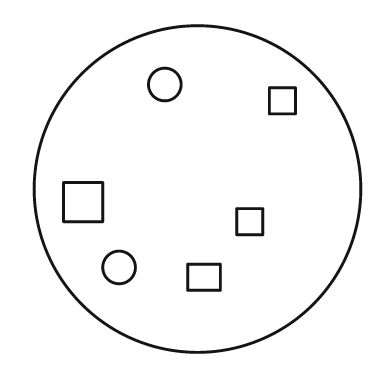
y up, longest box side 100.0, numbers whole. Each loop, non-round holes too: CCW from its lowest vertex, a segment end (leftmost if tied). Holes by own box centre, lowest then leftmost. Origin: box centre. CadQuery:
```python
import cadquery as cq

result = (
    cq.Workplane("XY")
    .moveTo(0.0, 0.0)
    .circle(50.0)
    .moveTo(-3.0, -31.0)
    .lineTo(7.0, -31.0)
    .lineTo(7.0, -23.0)
    .lineTo(-3.0, -23.0)
    .close()
    .moveTo(-24.0, -24.0)
    .circle(5.0)
    .moveTo(12.0, -14.0)
    .lineTo(20.0, -14.0)
    .lineTo(20.0, -6.0)
    .lineTo(12.0, -6.0)
    .close()
    .moveTo(-41.0, -10.0)
    .lineTo(-29.0, -10.0)
    .lineTo(-29.0, 2.0)
    .lineTo(-41.0, 2.0)
    .close()
    .moveTo(22.0, 23.0)
    .lineTo(30.0, 23.0)
    .lineTo(30.0, 31.0)
    .lineTo(22.0, 31.0)
    .close()
    .moveTo(-10.0, 32.0)
    .circle(5.0)
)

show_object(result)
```